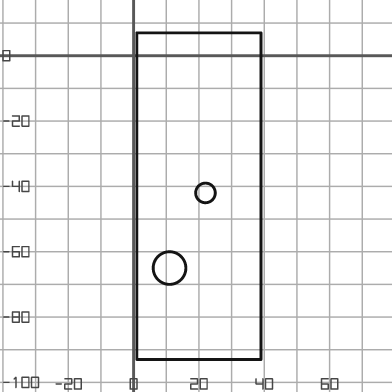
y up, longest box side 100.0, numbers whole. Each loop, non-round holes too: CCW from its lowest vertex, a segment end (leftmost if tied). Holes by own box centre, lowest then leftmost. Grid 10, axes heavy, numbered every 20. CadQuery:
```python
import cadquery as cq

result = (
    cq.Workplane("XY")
    .moveTo(1.0, -93.0)
    .lineTo(39.0, -93.0)
    .lineTo(39.0, 7.0)
    .lineTo(1.0, 7.0)
    .close()
    .moveTo(11.0, -65.0)
    .circle(5.0)
    .moveTo(22.0, -42.0)
    .circle(3.0)
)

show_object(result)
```